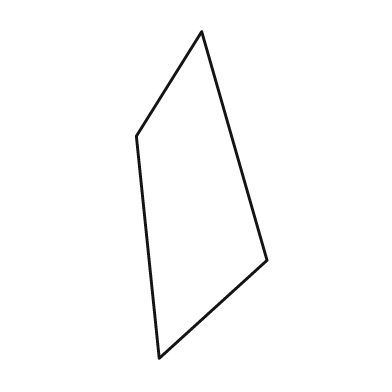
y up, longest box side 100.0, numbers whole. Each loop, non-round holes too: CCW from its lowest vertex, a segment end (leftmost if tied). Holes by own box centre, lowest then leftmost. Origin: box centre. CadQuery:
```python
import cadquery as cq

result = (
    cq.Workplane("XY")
    .moveTo(-13.0, -50.0)
    .lineTo(20.0, -20.0)
    .lineTo(0.0, 50.0)
    .lineTo(-20.0, 18.0)
    .close()
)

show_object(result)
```